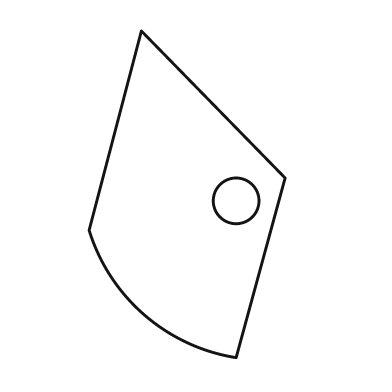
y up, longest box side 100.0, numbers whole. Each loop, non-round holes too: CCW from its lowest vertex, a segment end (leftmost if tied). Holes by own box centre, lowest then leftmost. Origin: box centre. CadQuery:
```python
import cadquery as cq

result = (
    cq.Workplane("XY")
    .moveTo(15.0, -50.0)
    .lineTo(30.0, 5.0)
    .lineTo(-14.0, 50.0)
    .lineTo(-30.0, -11.0)
    .threePointArc((-13.0, -37.0), (15.0, -50.0))
    .close()
    .moveTo(15.0, -2.0)
    .circle(7.0)
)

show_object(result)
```